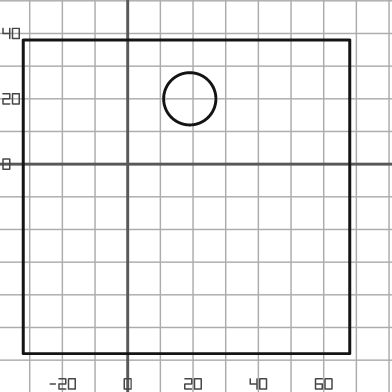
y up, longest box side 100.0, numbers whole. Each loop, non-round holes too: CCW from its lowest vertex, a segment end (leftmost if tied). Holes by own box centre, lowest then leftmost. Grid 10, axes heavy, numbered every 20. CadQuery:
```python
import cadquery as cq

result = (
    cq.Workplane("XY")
    .moveTo(-32.0, -58.0)
    .lineTo(68.0, -58.0)
    .lineTo(68.0, 38.0)
    .lineTo(-32.0, 38.0)
    .close()
    .moveTo(19.0, 20.0)
    .circle(8.0)
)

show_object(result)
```